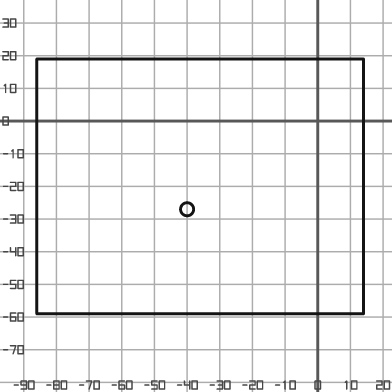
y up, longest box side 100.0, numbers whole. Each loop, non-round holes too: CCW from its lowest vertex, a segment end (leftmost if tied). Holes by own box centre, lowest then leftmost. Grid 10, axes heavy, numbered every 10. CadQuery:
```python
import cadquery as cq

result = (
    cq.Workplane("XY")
    .moveTo(-86.0, -59.0)
    .lineTo(14.0, -59.0)
    .lineTo(14.0, 19.0)
    .lineTo(-86.0, 19.0)
    .close()
    .moveTo(-40.0, -27.0)
    .circle(2.0)
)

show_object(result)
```